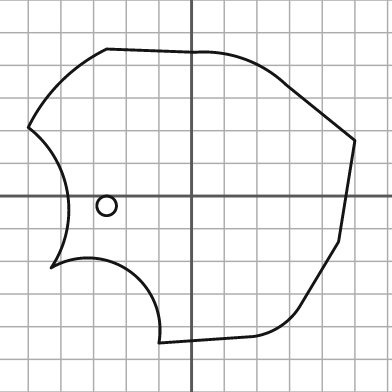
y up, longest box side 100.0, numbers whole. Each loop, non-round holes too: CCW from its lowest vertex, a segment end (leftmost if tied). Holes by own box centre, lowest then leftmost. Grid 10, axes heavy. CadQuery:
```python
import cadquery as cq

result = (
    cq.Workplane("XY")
    .moveTo(-10.0, -45.0)
    .lineTo(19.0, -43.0)
    .threePointArc((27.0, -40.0), (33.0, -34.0))
    .lineTo(45.0, -14.0)
    .lineTo(50.0, 17.0)
    .lineTo(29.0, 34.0)
    .threePointArc((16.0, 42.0), (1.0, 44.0))
    .lineTo(-26.0, 45.0)
    .threePointArc((-40.0, 35.0), (-50.0, 21.0))
    .threePointArc((-38.0, 1.0), (-43.0, -22.0))
    .threePointArc((-19.0, -23.0), (-10.0, -45.0))
    .close()
    .moveTo(-26.0, -3.0)
    .circle(3.0)
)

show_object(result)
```